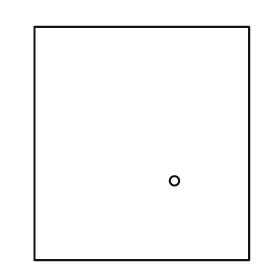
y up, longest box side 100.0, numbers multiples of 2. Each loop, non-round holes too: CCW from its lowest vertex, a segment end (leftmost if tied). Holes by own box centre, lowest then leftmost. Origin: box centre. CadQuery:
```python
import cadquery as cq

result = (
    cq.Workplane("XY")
    .moveTo(-46.0, -50.0)
    .lineTo(46.0, -50.0)
    .lineTo(46.0, 50.0)
    .lineTo(-46.0, 50.0)
    .close()
    .moveTo(14.0, -16.0)
    .circle(2.0)
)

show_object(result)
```